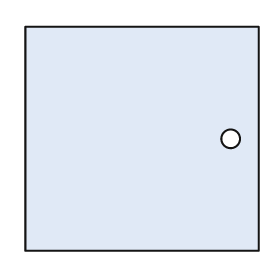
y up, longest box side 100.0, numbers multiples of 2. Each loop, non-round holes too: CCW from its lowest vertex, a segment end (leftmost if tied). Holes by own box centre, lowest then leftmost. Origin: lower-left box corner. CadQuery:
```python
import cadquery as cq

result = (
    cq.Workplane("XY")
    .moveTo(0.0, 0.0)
    .lineTo(100.0, 0.0)
    .lineTo(100.0, 96.0)
    .lineTo(0.0, 96.0)
    .close()
    .moveTo(88.0, 48.0)
    .circle(4.0)
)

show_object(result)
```